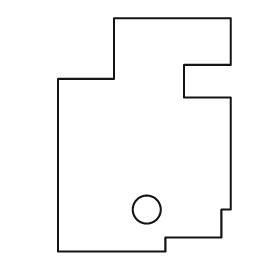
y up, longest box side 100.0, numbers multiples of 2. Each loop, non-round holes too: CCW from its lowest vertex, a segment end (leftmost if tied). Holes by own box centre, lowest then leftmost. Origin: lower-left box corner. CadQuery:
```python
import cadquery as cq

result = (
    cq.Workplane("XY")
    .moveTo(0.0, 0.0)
    .lineTo(46.0, 0.0)
    .lineTo(46.0, 6.0)
    .lineTo(70.0, 6.0)
    .lineTo(70.0, 18.0)
    .lineTo(74.0, 18.0)
    .lineTo(74.0, 66.0)
    .lineTo(54.0, 66.0)
    .lineTo(54.0, 80.0)
    .lineTo(74.0, 80.0)
    .lineTo(74.0, 100.0)
    .lineTo(24.0, 100.0)
    .lineTo(24.0, 74.0)
    .lineTo(0.0, 74.0)
    .close()
    .moveTo(38.0, 18.0)
    .circle(6.0)
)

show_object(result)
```